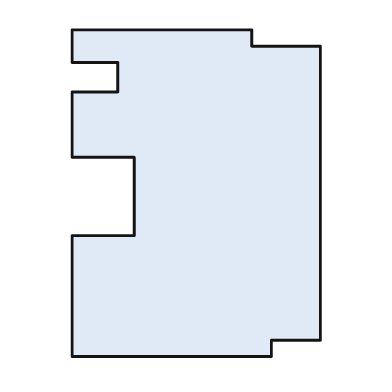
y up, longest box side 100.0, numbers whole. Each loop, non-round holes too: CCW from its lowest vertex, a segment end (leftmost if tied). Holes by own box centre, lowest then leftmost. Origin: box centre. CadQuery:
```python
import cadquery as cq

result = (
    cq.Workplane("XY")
    .moveTo(-38.0, -50.0)
    .lineTo(23.0, -50.0)
    .lineTo(23.0, -45.0)
    .lineTo(38.0, -45.0)
    .lineTo(38.0, 45.0)
    .lineTo(17.0, 45.0)
    .lineTo(17.0, 50.0)
    .lineTo(-38.0, 50.0)
    .lineTo(-38.0, 40.0)
    .lineTo(-24.0, 40.0)
    .lineTo(-24.0, 31.0)
    .lineTo(-38.0, 31.0)
    .lineTo(-38.0, 11.0)
    .lineTo(-19.0, 11.0)
    .lineTo(-19.0, -13.0)
    .lineTo(-38.0, -13.0)
    .close()
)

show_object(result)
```